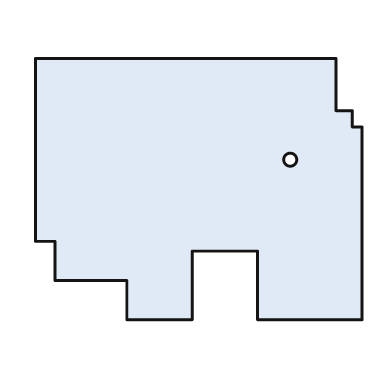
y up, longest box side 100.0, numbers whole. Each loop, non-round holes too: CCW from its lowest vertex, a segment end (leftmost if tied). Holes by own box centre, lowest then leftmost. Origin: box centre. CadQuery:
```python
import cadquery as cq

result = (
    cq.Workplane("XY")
    .moveTo(-22.0, -40.0)
    .lineTo(-2.0, -40.0)
    .lineTo(-2.0, -19.0)
    .lineTo(18.0, -19.0)
    .lineTo(18.0, -40.0)
    .lineTo(50.0, -40.0)
    .lineTo(50.0, 19.0)
    .lineTo(47.0, 19.0)
    .lineTo(47.0, 24.0)
    .lineTo(42.0, 24.0)
    .lineTo(42.0, 40.0)
    .lineTo(-50.0, 40.0)
    .lineTo(-50.0, -16.0)
    .lineTo(-44.0, -16.0)
    .lineTo(-44.0, -28.0)
    .lineTo(-22.0, -28.0)
    .close()
    .moveTo(28.0, 9.0)
    .circle(2.0)
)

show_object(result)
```